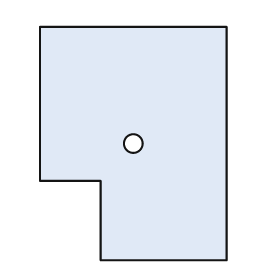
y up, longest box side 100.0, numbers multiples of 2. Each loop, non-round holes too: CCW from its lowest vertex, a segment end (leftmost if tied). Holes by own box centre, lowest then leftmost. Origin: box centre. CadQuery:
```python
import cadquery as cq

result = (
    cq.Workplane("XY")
    .moveTo(-14.0, -50.0)
    .lineTo(40.0, -50.0)
    .lineTo(40.0, 50.0)
    .lineTo(-40.0, 50.0)
    .lineTo(-40.0, -16.0)
    .lineTo(-14.0, -16.0)
    .close()
    .moveTo(0.0, 0.0)
    .circle(4.0)
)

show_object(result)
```